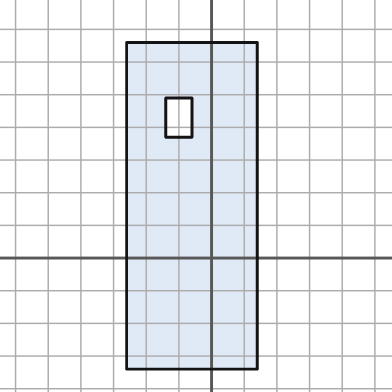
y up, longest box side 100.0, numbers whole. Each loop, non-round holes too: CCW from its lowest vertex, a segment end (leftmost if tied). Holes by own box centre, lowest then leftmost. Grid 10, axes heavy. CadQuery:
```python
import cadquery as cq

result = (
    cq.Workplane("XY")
    .moveTo(-26.0, -34.0)
    .lineTo(14.0, -34.0)
    .lineTo(14.0, 66.0)
    .lineTo(-26.0, 66.0)
    .close()
    .moveTo(-14.0, 37.0)
    .lineTo(-6.0, 37.0)
    .lineTo(-6.0, 49.0)
    .lineTo(-14.0, 49.0)
    .close()
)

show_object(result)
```